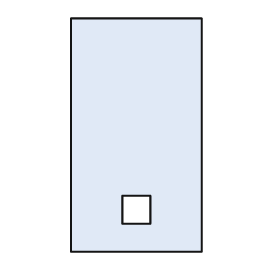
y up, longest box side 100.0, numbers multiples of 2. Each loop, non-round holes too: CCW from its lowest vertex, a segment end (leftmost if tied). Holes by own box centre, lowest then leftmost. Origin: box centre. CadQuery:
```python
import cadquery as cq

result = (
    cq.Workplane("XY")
    .moveTo(-28.0, -50.0)
    .lineTo(28.0, -50.0)
    .lineTo(28.0, 50.0)
    .lineTo(-28.0, 50.0)
    .close()
    .moveTo(-6.0, -38.0)
    .lineTo(6.0, -38.0)
    .lineTo(6.0, -26.0)
    .lineTo(-6.0, -26.0)
    .close()
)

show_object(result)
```